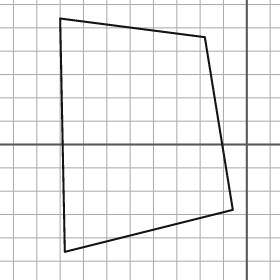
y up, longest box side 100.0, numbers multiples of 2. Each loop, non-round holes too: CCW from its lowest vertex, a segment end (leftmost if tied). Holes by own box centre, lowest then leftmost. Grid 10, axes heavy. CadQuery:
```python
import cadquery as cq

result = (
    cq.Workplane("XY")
    .moveTo(-78.0, -46.0)
    .lineTo(-6.0, -28.0)
    .lineTo(-18.0, 46.0)
    .lineTo(-80.0, 54.0)
    .close()
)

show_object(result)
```